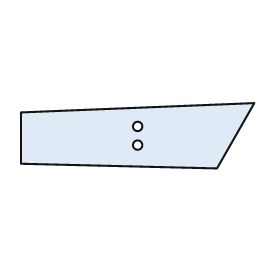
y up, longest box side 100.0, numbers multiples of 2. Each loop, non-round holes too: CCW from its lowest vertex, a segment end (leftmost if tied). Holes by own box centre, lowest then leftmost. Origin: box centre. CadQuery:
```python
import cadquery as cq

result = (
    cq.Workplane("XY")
    .moveTo(34.0, -14.0)
    .lineTo(50.0, 14.0)
    .lineTo(-50.0, 10.0)
    .lineTo(-50.0, -12.0)
    .close()
    .moveTo(0.0, -4.0)
    .circle(2.0)
    .moveTo(0.0, 4.0)
    .circle(2.0)
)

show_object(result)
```